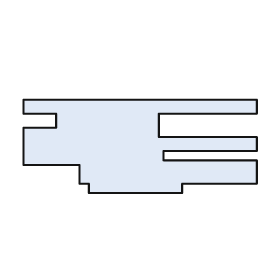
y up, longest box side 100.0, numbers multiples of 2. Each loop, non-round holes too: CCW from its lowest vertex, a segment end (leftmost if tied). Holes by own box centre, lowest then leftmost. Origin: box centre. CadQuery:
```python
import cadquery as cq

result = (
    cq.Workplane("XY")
    .moveTo(-22.0, -20.0)
    .lineTo(18.0, -20.0)
    .lineTo(18.0, -16.0)
    .lineTo(50.0, -16.0)
    .lineTo(50.0, -6.0)
    .lineTo(10.0, -6.0)
    .lineTo(10.0, -2.0)
    .lineTo(50.0, -2.0)
    .lineTo(50.0, 4.0)
    .lineTo(8.0, 4.0)
    .lineTo(8.0, 14.0)
    .lineTo(50.0, 14.0)
    .lineTo(50.0, 20.0)
    .lineTo(-50.0, 20.0)
    .lineTo(-50.0, 14.0)
    .lineTo(-36.0, 14.0)
    .lineTo(-36.0, 8.0)
    .lineTo(-50.0, 8.0)
    .lineTo(-50.0, -8.0)
    .lineTo(-26.0, -8.0)
    .lineTo(-26.0, -16.0)
    .lineTo(-22.0, -16.0)
    .close()
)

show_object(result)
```